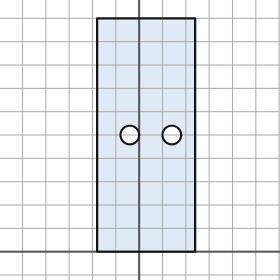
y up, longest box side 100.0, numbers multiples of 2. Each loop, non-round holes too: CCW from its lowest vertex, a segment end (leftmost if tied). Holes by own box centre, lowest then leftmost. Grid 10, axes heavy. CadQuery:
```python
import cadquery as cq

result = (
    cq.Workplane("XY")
    .moveTo(-18.0, 0.0)
    .lineTo(24.0, 0.0)
    .lineTo(24.0, 100.0)
    .lineTo(-18.0, 100.0)
    .close()
    .moveTo(-4.0, 50.0)
    .circle(4.0)
    .moveTo(14.0, 50.0)
    .circle(4.0)
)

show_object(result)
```